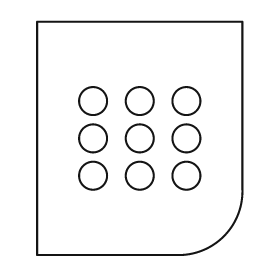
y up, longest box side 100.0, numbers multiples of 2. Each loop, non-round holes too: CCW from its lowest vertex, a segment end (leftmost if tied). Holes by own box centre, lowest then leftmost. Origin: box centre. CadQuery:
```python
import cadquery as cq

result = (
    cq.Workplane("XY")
    .moveTo(-44.0, -50.0)
    .lineTo(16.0, -50.0)
    .threePointArc((36.0, -42.0), (44.0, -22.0))
    .lineTo(44.0, 50.0)
    .lineTo(-44.0, 50.0)
    .close()
    .moveTo(-20.0, -16.0)
    .circle(6.0)
    .moveTo(0.0, -16.0)
    .circle(6.0)
    .moveTo(20.0, -16.0)
    .circle(6.0)
    .moveTo(-20.0, 0.0)
    .circle(6.0)
    .moveTo(0.0, 0.0)
    .circle(6.0)
    .moveTo(20.0, 0.0)
    .circle(6.0)
    .moveTo(-20.0, 16.0)
    .circle(6.0)
    .moveTo(0.0, 16.0)
    .circle(6.0)
    .moveTo(20.0, 16.0)
    .circle(6.0)
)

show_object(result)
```